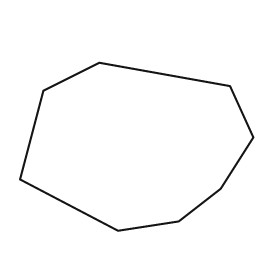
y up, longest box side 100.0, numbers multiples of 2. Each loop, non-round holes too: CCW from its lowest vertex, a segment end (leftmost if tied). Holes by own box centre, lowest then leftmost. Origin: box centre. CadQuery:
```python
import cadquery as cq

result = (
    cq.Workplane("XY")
    .moveTo(-8.0, -36.0)
    .lineTo(18.0, -32.0)
    .lineTo(36.0, -18.0)
    .lineTo(50.0, 4.0)
    .lineTo(40.0, 26.0)
    .lineTo(-16.0, 36.0)
    .lineTo(-40.0, 24.0)
    .lineTo(-50.0, -14.0)
    .close()
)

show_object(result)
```